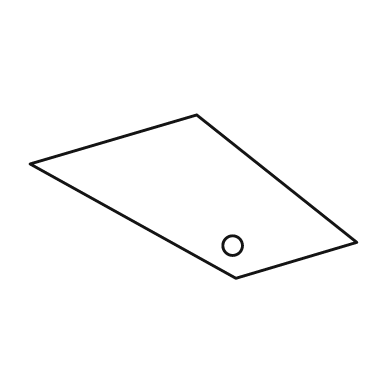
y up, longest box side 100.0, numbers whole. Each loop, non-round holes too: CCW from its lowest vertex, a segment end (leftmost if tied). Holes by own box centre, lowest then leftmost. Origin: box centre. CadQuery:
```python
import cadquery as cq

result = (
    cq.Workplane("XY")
    .moveTo(13.0, -25.0)
    .lineTo(50.0, -14.0)
    .lineTo(1.0, 25.0)
    .lineTo(-50.0, 10.0)
    .close()
    .moveTo(12.0, -15.0)
    .circle(3.0)
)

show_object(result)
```